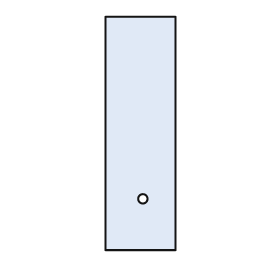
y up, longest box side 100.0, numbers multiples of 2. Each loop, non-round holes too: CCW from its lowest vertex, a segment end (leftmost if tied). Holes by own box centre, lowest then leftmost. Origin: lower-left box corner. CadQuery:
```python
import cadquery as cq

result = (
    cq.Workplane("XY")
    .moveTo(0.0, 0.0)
    .lineTo(30.0, 0.0)
    .lineTo(30.0, 100.0)
    .lineTo(0.0, 100.0)
    .close()
    .moveTo(16.0, 22.0)
    .circle(2.0)
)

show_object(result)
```